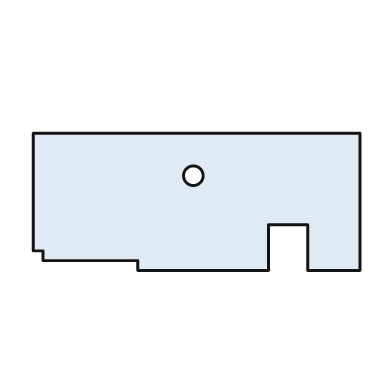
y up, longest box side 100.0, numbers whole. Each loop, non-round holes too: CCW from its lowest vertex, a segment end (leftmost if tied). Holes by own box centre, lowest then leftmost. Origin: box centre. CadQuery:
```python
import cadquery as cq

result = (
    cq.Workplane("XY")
    .moveTo(-18.0, -21.0)
    .lineTo(22.0, -21.0)
    .lineTo(22.0, -7.0)
    .lineTo(34.0, -7.0)
    .lineTo(34.0, -21.0)
    .lineTo(50.0, -21.0)
    .lineTo(50.0, 21.0)
    .lineTo(-50.0, 21.0)
    .lineTo(-50.0, -15.0)
    .lineTo(-47.0, -15.0)
    .lineTo(-47.0, -18.0)
    .lineTo(-18.0, -18.0)
    .close()
    .moveTo(-1.0, 8.0)
    .circle(3.0)
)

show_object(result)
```